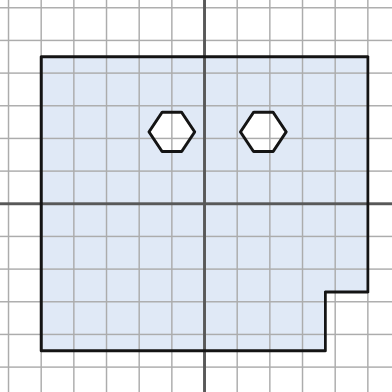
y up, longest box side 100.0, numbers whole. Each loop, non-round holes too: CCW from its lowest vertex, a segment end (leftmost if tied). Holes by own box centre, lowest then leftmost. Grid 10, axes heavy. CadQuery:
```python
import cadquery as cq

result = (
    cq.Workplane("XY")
    .moveTo(-50.0, -45.0)
    .lineTo(37.0, -45.0)
    .lineTo(37.0, -27.0)
    .lineTo(50.0, -27.0)
    .lineTo(50.0, 45.0)
    .lineTo(-50.0, 45.0)
    .close()
    .moveTo(-13.0, 16.0)
    .lineTo(-7.0, 16.0)
    .lineTo(-3.0, 22.0)
    .lineTo(-7.0, 28.0)
    .lineTo(-13.0, 28.0)
    .lineTo(-17.0, 22.0)
    .close()
    .moveTo(15.0, 16.0)
    .lineTo(21.0, 16.0)
    .lineTo(25.0, 22.0)
    .lineTo(21.0, 28.0)
    .lineTo(15.0, 28.0)
    .lineTo(11.0, 22.0)
    .close()
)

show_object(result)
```